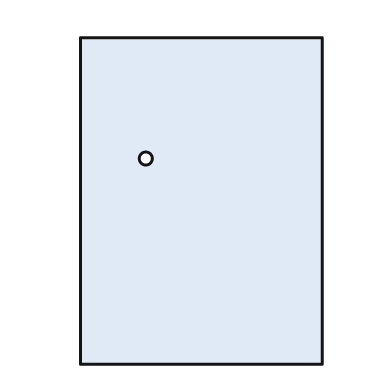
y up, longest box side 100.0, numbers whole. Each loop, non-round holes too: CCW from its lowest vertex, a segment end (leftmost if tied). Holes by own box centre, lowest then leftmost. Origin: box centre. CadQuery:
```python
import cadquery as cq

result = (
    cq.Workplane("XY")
    .moveTo(-37.0, -50.0)
    .lineTo(37.0, -50.0)
    .lineTo(37.0, 50.0)
    .lineTo(-37.0, 50.0)
    .close()
    .moveTo(-17.0, 13.0)
    .circle(2.0)
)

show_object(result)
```